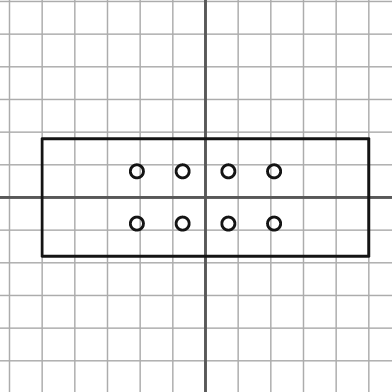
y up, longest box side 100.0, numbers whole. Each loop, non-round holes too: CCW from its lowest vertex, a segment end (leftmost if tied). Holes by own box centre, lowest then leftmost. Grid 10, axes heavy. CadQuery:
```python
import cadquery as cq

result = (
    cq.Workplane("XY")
    .moveTo(-50.0, -18.0)
    .lineTo(50.0, -18.0)
    .lineTo(50.0, 18.0)
    .lineTo(-50.0, 18.0)
    .close()
    .moveTo(-21.0, -8.0)
    .circle(2.0)
    .moveTo(-7.0, -8.0)
    .circle(2.0)
    .moveTo(7.0, -8.0)
    .circle(2.0)
    .moveTo(21.0, -8.0)
    .circle(2.0)
    .moveTo(-21.0, 8.0)
    .circle(2.0)
    .moveTo(-7.0, 8.0)
    .circle(2.0)
    .moveTo(7.0, 8.0)
    .circle(2.0)
    .moveTo(21.0, 8.0)
    .circle(2.0)
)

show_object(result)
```